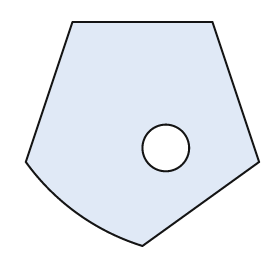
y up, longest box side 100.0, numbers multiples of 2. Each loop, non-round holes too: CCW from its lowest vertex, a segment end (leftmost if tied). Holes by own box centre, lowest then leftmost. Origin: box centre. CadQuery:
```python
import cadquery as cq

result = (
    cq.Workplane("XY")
    .moveTo(0.0, -48.0)
    .lineTo(50.0, -12.0)
    .lineTo(30.0, 48.0)
    .lineTo(-30.0, 48.0)
    .lineTo(-50.0, -12.0)
    .threePointArc((-28.0, -34.0), (0.0, -48.0))
    .close()
    .moveTo(10.0, -6.0)
    .circle(10.0)
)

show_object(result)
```